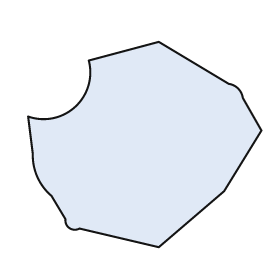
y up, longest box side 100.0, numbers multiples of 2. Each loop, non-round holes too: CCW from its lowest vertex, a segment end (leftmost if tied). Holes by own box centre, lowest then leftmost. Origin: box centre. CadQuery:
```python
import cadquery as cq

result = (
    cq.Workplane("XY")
    .moveTo(6.0, -44.0)
    .lineTo(34.0, -20.0)
    .lineTo(50.0, 6.0)
    .lineTo(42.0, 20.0)
    .threePointArc((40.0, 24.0), (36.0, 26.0))
    .lineTo(6.0, 44.0)
    .lineTo(-24.0, 36.0)
    .threePointArc((-30.0, 16.0), (-50.0, 12.0))
    .lineTo(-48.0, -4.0)
    .threePointArc((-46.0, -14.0), (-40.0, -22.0))
    .lineTo(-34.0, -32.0)
    .threePointArc((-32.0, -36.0), (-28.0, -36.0))
    .close()
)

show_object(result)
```